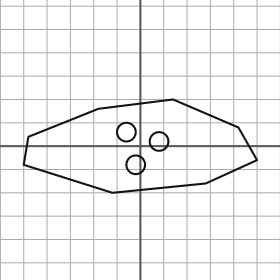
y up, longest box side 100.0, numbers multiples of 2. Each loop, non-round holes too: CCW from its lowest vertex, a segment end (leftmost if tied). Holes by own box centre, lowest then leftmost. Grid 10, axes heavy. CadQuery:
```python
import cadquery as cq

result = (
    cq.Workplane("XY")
    .moveTo(-12.0, -20.0)
    .lineTo(28.0, -16.0)
    .lineTo(50.0, -6.0)
    .lineTo(42.0, 8.0)
    .lineTo(14.0, 20.0)
    .lineTo(-18.0, 16.0)
    .lineTo(-48.0, 4.0)
    .lineTo(-50.0, -8.0)
    .close()
    .moveTo(-2.0, -8.0)
    .circle(4.0)
    .moveTo(8.0, 2.0)
    .circle(4.0)
    .moveTo(-6.0, 6.0)
    .circle(4.0)
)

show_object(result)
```